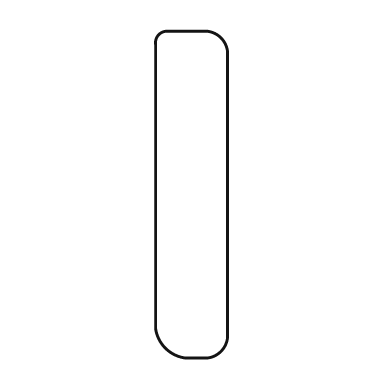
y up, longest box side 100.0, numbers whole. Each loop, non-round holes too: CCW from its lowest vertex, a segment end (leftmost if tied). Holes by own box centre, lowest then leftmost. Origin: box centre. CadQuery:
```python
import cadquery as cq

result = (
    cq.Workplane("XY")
    .moveTo(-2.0, -50.0)
    .lineTo(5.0, -50.0)
    .threePointArc((9.0, -48.0), (11.0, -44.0))
    .lineTo(11.0, 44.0)
    .threePointArc((9.0, 48.0), (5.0, 50.0))
    .lineTo(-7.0, 50.0)
    .threePointArc((-10.0, 49.0), (-11.0, 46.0))
    .lineTo(-11.0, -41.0)
    .threePointArc((-8.0, -47.0), (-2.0, -50.0))
    .close()
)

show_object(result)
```